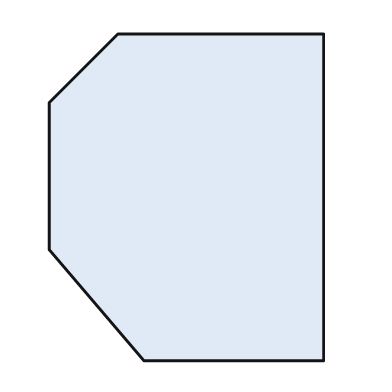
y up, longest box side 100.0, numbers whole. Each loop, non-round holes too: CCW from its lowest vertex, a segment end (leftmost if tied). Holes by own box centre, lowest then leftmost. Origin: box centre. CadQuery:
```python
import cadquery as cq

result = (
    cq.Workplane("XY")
    .moveTo(-13.0, -50.0)
    .lineTo(42.0, -50.0)
    .lineTo(42.0, 50.0)
    .lineTo(-21.0, 50.0)
    .lineTo(-42.0, 29.0)
    .lineTo(-42.0, -16.0)
    .close()
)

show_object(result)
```